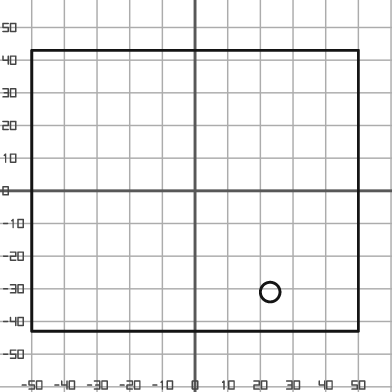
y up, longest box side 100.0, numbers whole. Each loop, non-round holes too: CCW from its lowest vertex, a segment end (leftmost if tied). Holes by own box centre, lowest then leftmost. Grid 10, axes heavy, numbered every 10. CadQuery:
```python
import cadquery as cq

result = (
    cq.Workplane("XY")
    .moveTo(-50.0, -43.0)
    .lineTo(50.0, -43.0)
    .lineTo(50.0, 43.0)
    .lineTo(-50.0, 43.0)
    .close()
    .moveTo(23.0, -31.0)
    .circle(3.0)
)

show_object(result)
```